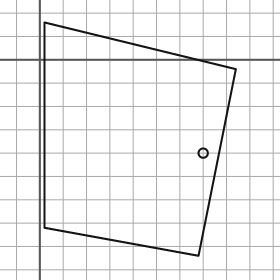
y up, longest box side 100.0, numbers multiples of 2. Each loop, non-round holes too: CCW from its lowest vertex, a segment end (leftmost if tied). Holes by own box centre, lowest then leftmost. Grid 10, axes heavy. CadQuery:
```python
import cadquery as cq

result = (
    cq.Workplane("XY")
    .moveTo(68.0, -84.0)
    .lineTo(84.0, -4.0)
    .lineTo(2.0, 16.0)
    .lineTo(2.0, -72.0)
    .close()
    .moveTo(70.0, -40.0)
    .circle(2.0)
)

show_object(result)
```